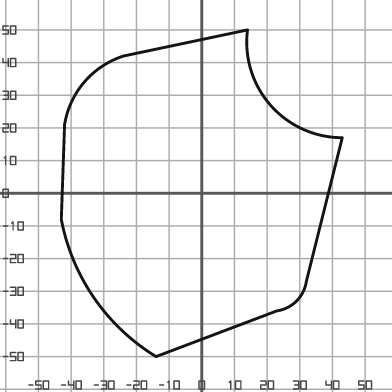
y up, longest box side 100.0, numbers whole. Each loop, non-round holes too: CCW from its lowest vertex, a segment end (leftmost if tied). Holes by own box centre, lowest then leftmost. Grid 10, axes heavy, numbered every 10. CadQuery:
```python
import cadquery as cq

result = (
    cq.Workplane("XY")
    .moveTo(-14.0, -50.0)
    .lineTo(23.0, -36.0)
    .threePointArc((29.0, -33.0), (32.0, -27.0))
    .lineTo(43.0, 17.0)
    .threePointArc((21.0, 27.0), (14.0, 50.0))
    .lineTo(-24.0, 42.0)
    .threePointArc((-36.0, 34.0), (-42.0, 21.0))
    .lineTo(-43.0, -8.0)
    .threePointArc((-33.0, -32.0), (-14.0, -50.0))
    .close()
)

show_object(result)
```